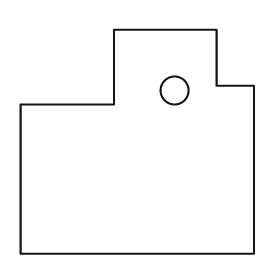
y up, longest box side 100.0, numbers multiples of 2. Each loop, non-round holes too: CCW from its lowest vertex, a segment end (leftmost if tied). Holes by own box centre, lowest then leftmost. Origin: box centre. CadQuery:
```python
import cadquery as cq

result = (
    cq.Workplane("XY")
    .moveTo(-50.0, -48.0)
    .lineTo(50.0, -48.0)
    .lineTo(50.0, 24.0)
    .lineTo(34.0, 24.0)
    .lineTo(34.0, 48.0)
    .lineTo(-10.0, 48.0)
    .lineTo(-10.0, 16.0)
    .lineTo(-50.0, 16.0)
    .close()
    .moveTo(16.0, 22.0)
    .circle(6.0)
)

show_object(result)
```